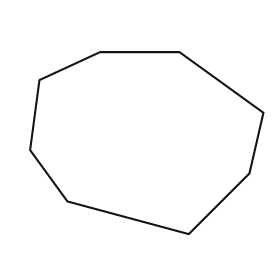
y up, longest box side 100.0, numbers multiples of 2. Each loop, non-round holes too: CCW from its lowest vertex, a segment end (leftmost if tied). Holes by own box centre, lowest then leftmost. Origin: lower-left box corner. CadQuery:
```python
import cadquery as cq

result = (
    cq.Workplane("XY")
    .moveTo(68.0, 0.0)
    .lineTo(94.0, 26.0)
    .lineTo(100.0, 52.0)
    .lineTo(64.0, 78.0)
    .lineTo(30.0, 78.0)
    .lineTo(4.0, 66.0)
    .lineTo(0.0, 36.0)
    .lineTo(16.0, 14.0)
    .close()
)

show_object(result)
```